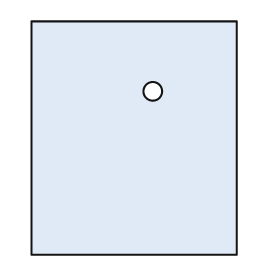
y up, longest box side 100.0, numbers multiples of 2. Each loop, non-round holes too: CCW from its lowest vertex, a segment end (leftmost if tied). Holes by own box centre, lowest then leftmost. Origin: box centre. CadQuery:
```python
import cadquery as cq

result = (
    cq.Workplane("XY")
    .moveTo(-44.0, -50.0)
    .lineTo(44.0, -50.0)
    .lineTo(44.0, 50.0)
    .lineTo(-44.0, 50.0)
    .close()
    .moveTo(8.0, 20.0)
    .circle(4.0)
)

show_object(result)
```